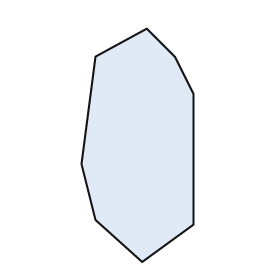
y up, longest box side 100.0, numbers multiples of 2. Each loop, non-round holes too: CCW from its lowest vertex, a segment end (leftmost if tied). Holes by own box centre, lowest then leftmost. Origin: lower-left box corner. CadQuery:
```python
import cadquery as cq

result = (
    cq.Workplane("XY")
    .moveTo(26.0, 0.0)
    .lineTo(48.0, 16.0)
    .lineTo(48.0, 72.0)
    .lineTo(40.0, 88.0)
    .lineTo(28.0, 100.0)
    .lineTo(6.0, 88.0)
    .lineTo(0.0, 42.0)
    .lineTo(6.0, 18.0)
    .close()
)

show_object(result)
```